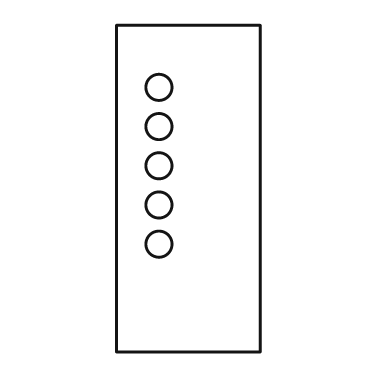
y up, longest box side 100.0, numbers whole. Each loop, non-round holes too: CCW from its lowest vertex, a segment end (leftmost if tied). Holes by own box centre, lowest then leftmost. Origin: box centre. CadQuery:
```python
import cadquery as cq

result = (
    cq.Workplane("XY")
    .moveTo(-22.0, -50.0)
    .lineTo(22.0, -50.0)
    .lineTo(22.0, 50.0)
    .lineTo(-22.0, 50.0)
    .close()
    .moveTo(-9.0, -17.0)
    .circle(4.0)
    .moveTo(-9.0, -5.0)
    .circle(4.0)
    .moveTo(-9.0, 7.0)
    .circle(4.0)
    .moveTo(-9.0, 19.0)
    .circle(4.0)
    .moveTo(-9.0, 31.0)
    .circle(4.0)
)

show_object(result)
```